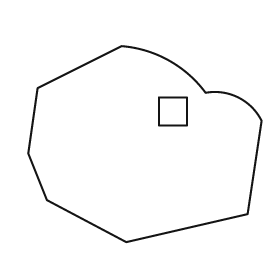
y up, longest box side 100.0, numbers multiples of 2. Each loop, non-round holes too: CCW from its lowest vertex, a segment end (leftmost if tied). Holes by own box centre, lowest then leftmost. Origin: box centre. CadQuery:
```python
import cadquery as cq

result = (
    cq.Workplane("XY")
    .moveTo(-8.0, -42.0)
    .lineTo(44.0, -30.0)
    .lineTo(50.0, 10.0)
    .threePointArc((40.0, 20.0), (26.0, 22.0))
    .threePointArc((10.0, 36.0), (-10.0, 42.0))
    .lineTo(-46.0, 24.0)
    .lineTo(-50.0, -4.0)
    .lineTo(-42.0, -24.0)
    .close()
    .moveTo(6.0, 8.0)
    .lineTo(18.0, 8.0)
    .lineTo(18.0, 20.0)
    .lineTo(6.0, 20.0)
    .close()
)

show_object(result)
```